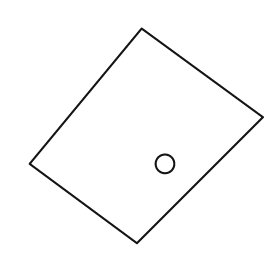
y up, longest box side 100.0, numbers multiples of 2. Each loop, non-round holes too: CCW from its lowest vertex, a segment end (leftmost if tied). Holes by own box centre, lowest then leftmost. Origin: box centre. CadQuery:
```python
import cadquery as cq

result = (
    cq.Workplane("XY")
    .moveTo(-4.0, -46.0)
    .lineTo(50.0, 8.0)
    .lineTo(-2.0, 46.0)
    .lineTo(-50.0, -12.0)
    .close()
    .moveTo(8.0, -12.0)
    .circle(4.0)
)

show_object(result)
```